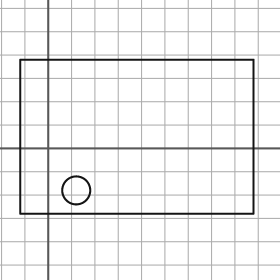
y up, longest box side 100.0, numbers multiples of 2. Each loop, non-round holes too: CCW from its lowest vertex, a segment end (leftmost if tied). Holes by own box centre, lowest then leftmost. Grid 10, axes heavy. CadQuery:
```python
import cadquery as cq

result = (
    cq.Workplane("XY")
    .moveTo(-12.0, -28.0)
    .lineTo(88.0, -28.0)
    .lineTo(88.0, 38.0)
    .lineTo(-12.0, 38.0)
    .close()
    .moveTo(12.0, -18.0)
    .circle(6.0)
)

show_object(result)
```